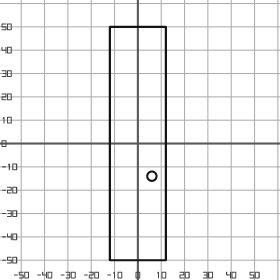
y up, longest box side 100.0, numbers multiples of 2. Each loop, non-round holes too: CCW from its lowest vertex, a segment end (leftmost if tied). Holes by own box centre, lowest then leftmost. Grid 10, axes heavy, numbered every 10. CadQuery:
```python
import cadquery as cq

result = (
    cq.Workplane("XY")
    .moveTo(-12.0, -50.0)
    .lineTo(12.0, -50.0)
    .lineTo(12.0, 50.0)
    .lineTo(-12.0, 50.0)
    .close()
    .moveTo(6.0, -14.0)
    .circle(2.0)
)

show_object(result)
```